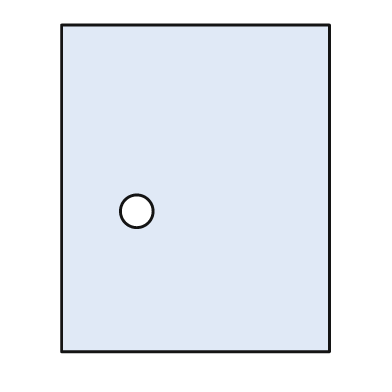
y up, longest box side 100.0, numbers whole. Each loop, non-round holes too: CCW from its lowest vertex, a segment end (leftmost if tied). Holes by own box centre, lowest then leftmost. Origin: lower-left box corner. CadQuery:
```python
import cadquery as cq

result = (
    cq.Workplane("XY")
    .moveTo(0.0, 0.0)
    .lineTo(82.0, 0.0)
    .lineTo(82.0, 100.0)
    .lineTo(0.0, 100.0)
    .close()
    .moveTo(23.0, 43.0)
    .circle(5.0)
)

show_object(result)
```